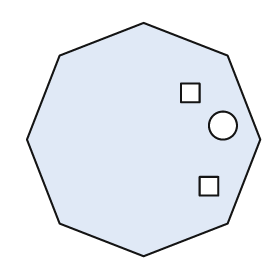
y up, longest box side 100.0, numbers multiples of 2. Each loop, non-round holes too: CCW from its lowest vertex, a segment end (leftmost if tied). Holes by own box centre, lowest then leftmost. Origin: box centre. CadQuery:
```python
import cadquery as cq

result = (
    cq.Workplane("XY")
    .moveTo(0.0, -50.0)
    .lineTo(36.0, -36.0)
    .lineTo(50.0, 0.0)
    .lineTo(36.0, 36.0)
    .lineTo(0.0, 50.0)
    .lineTo(-36.0, 36.0)
    .lineTo(-50.0, 0.0)
    .lineTo(-36.0, -36.0)
    .close()
    .moveTo(24.0, -24.0)
    .lineTo(32.0, -24.0)
    .lineTo(32.0, -16.0)
    .lineTo(24.0, -16.0)
    .close()
    .moveTo(34.0, 6.0)
    .circle(6.0)
    .moveTo(16.0, 16.0)
    .lineTo(24.0, 16.0)
    .lineTo(24.0, 24.0)
    .lineTo(16.0, 24.0)
    .close()
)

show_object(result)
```